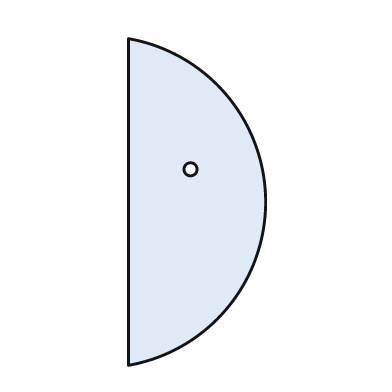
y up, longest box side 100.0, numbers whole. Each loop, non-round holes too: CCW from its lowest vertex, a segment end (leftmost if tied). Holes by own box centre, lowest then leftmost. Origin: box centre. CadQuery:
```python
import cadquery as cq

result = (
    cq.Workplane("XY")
    .moveTo(-21.0, -50.0)
    .threePointArc((21.0, 0.0), (-21.0, 50.0))
    .close()
    .moveTo(-2.0, 10.0)
    .circle(2.0)
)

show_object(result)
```